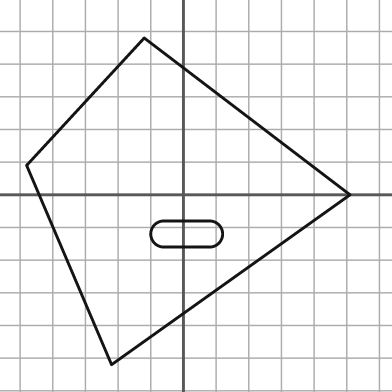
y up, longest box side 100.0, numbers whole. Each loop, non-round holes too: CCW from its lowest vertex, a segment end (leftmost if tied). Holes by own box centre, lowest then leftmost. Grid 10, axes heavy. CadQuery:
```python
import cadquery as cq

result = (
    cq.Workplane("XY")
    .moveTo(-22.0, -52.0)
    .lineTo(51.0, 0.0)
    .lineTo(-12.0, 48.0)
    .lineTo(-48.0, 9.0)
    .close()
    .moveTo(-6.0, -16.0)
    .lineTo(8.0, -16.0)
    .threePointArc((12.0, -12.0), (8.0, -8.0))
    .lineTo(-6.0, -8.0)
    .threePointArc((-10.0, -12.0), (-6.0, -16.0))
    .close()
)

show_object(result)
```